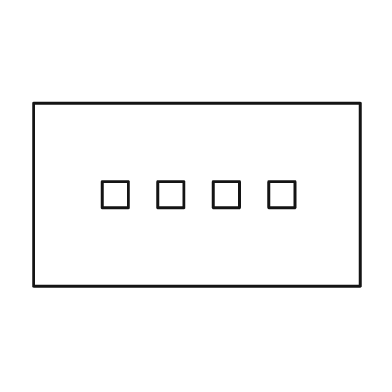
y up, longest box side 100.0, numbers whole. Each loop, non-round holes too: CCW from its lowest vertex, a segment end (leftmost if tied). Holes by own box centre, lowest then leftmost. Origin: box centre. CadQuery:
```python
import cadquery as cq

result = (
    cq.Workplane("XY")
    .moveTo(-50.0, -28.0)
    .lineTo(50.0, -28.0)
    .lineTo(50.0, 28.0)
    .lineTo(-50.0, 28.0)
    .close()
    .moveTo(-29.0, -4.0)
    .lineTo(-21.0, -4.0)
    .lineTo(-21.0, 4.0)
    .lineTo(-29.0, 4.0)
    .close()
    .moveTo(-12.0, -4.0)
    .lineTo(-4.0, -4.0)
    .lineTo(-4.0, 4.0)
    .lineTo(-12.0, 4.0)
    .close()
    .moveTo(5.0, -4.0)
    .lineTo(13.0, -4.0)
    .lineTo(13.0, 4.0)
    .lineTo(5.0, 4.0)
    .close()
    .moveTo(22.0, -4.0)
    .lineTo(30.0, -4.0)
    .lineTo(30.0, 4.0)
    .lineTo(22.0, 4.0)
    .close()
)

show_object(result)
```